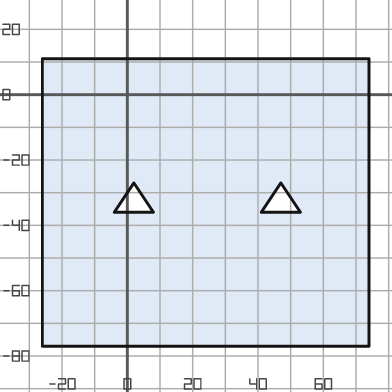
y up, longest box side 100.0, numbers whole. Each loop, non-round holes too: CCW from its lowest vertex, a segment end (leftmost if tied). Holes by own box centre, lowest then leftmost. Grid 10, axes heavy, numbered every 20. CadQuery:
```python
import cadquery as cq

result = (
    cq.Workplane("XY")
    .moveTo(-26.0, -77.0)
    .lineTo(74.0, -77.0)
    .lineTo(74.0, 11.0)
    .lineTo(-26.0, 11.0)
    .close()
    .moveTo(-4.0, -36.0)
    .lineTo(8.0, -36.0)
    .lineTo(2.0, -27.0)
    .close()
    .moveTo(41.0, -36.0)
    .lineTo(53.0, -36.0)
    .lineTo(47.0, -27.0)
    .close()
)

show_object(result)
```